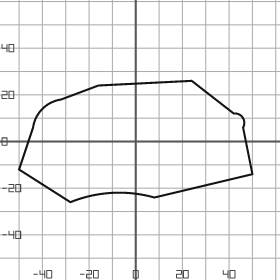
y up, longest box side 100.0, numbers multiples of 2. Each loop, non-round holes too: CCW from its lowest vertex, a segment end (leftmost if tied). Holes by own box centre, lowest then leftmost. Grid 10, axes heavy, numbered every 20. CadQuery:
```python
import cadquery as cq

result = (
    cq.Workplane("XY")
    .moveTo(-28.0, -26.0)
    .threePointArc((-10.0, -22.0), (8.0, -24.0))
    .lineTo(50.0, -14.0)
    .lineTo(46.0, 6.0)
    .threePointArc((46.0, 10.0), (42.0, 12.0))
    .lineTo(24.0, 26.0)
    .lineTo(-16.0, 24.0)
    .lineTo(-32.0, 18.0)
    .threePointArc((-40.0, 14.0), (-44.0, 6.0))
    .lineTo(-50.0, -12.0)
    .close()
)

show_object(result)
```